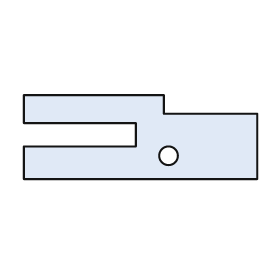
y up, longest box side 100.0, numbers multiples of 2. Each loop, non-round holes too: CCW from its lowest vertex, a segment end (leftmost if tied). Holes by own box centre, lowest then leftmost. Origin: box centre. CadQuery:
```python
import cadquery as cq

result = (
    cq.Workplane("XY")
    .moveTo(-50.0, -18.0)
    .lineTo(50.0, -18.0)
    .lineTo(50.0, 10.0)
    .lineTo(10.0, 10.0)
    .lineTo(10.0, 18.0)
    .lineTo(-50.0, 18.0)
    .lineTo(-50.0, 6.0)
    .lineTo(-2.0, 6.0)
    .lineTo(-2.0, -4.0)
    .lineTo(-50.0, -4.0)
    .close()
    .moveTo(12.0, -8.0)
    .circle(4.0)
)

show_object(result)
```